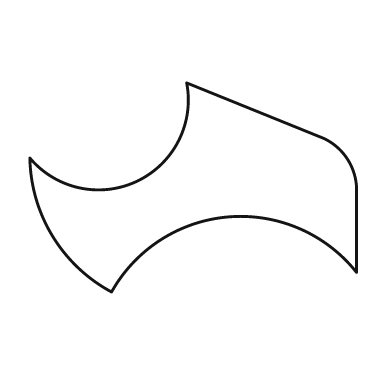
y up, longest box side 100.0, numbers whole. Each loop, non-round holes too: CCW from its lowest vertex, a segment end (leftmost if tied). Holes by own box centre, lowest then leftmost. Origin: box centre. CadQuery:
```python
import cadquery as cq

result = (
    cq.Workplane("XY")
    .moveTo(-25.0, -32.0)
    .threePointArc((11.0, -9.0), (50.0, -26.0))
    .lineTo(50.0, 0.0)
    .threePointArc((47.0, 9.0), (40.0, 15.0))
    .lineTo(-2.0, 32.0)
    .threePointArc((-17.0, 2.0), (-50.0, 9.0))
    .threePointArc((-43.0, -15.0), (-25.0, -32.0))
    .close()
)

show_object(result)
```